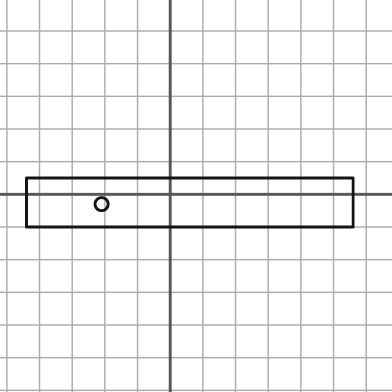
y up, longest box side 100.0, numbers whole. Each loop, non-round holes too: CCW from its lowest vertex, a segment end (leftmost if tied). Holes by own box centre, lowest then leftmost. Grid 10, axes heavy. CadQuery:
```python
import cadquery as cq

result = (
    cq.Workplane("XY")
    .moveTo(-44.0, -10.0)
    .lineTo(56.0, -10.0)
    .lineTo(56.0, 5.0)
    .lineTo(-44.0, 5.0)
    .close()
    .moveTo(-21.0, -3.0)
    .circle(2.0)
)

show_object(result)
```